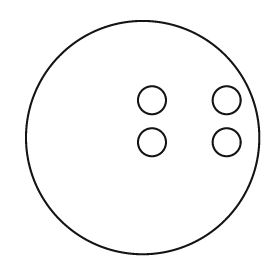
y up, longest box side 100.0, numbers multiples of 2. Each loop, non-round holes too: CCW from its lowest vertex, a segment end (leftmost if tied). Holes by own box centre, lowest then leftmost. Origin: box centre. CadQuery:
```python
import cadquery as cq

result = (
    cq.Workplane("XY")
    .moveTo(0.0, 0.0)
    .circle(50.0)
    .moveTo(4.0, -2.0)
    .circle(6.0)
    .moveTo(36.0, -2.0)
    .circle(6.0)
    .moveTo(4.0, 16.0)
    .circle(6.0)
    .moveTo(36.0, 16.0)
    .circle(6.0)
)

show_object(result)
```